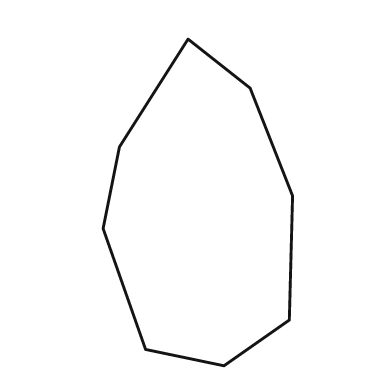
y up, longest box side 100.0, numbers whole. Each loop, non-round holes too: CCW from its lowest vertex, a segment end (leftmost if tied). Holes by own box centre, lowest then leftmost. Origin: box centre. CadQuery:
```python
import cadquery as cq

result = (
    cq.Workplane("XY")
    .moveTo(8.0, -50.0)
    .lineTo(28.0, -36.0)
    .lineTo(29.0, 2.0)
    .lineTo(16.0, 35.0)
    .lineTo(-3.0, 50.0)
    .lineTo(-24.0, 17.0)
    .lineTo(-29.0, -8.0)
    .lineTo(-16.0, -45.0)
    .close()
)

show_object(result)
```